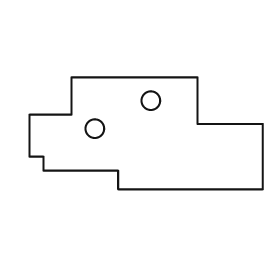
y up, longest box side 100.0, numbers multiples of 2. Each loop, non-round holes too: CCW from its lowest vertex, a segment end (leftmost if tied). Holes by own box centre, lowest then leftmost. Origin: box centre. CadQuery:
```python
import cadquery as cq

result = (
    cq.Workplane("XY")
    .moveTo(-12.0, -24.0)
    .lineTo(50.0, -24.0)
    .lineTo(50.0, 4.0)
    .lineTo(22.0, 4.0)
    .lineTo(22.0, 24.0)
    .lineTo(-32.0, 24.0)
    .lineTo(-32.0, 8.0)
    .lineTo(-50.0, 8.0)
    .lineTo(-50.0, -10.0)
    .lineTo(-44.0, -10.0)
    .lineTo(-44.0, -16.0)
    .lineTo(-12.0, -16.0)
    .close()
    .moveTo(-22.0, 2.0)
    .circle(4.0)
    .moveTo(2.0, 14.0)
    .circle(4.0)
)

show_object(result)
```